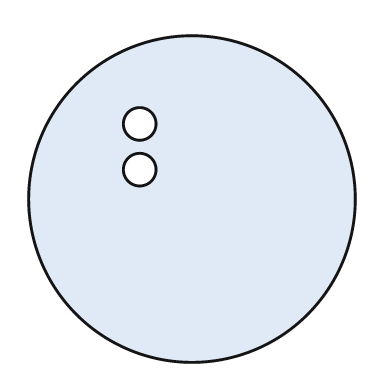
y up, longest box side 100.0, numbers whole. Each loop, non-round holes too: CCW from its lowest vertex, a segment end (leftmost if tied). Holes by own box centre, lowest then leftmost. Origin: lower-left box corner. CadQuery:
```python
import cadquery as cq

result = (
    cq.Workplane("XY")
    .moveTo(50.0, 50.0)
    .circle(50.0)
    .moveTo(34.0, 59.0)
    .circle(5.0)
    .moveTo(34.0, 73.0)
    .circle(5.0)
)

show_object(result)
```